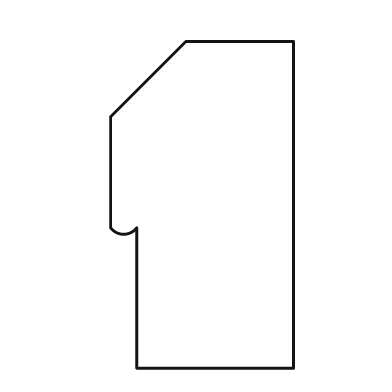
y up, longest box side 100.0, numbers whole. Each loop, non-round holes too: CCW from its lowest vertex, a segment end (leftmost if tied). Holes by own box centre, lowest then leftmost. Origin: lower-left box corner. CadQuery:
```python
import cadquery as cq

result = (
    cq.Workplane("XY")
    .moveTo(8.0, 0.0)
    .lineTo(56.0, 0.0)
    .lineTo(56.0, 100.0)
    .lineTo(23.0, 100.0)
    .lineTo(0.0, 77.0)
    .lineTo(0.0, 43.0)
    .threePointArc((4.0, 41.0), (8.0, 43.0))
    .close()
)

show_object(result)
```